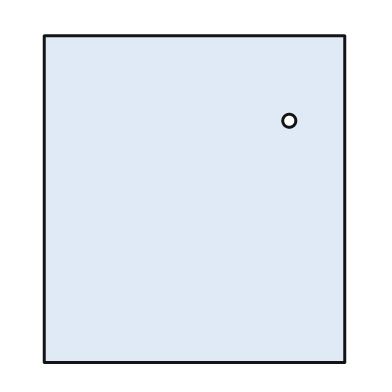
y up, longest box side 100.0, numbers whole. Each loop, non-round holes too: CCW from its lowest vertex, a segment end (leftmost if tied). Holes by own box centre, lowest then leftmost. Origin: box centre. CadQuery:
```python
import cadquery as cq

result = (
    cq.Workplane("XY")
    .moveTo(-46.0, -50.0)
    .lineTo(46.0, -50.0)
    .lineTo(46.0, 50.0)
    .lineTo(-46.0, 50.0)
    .close()
    .moveTo(29.0, 24.0)
    .circle(2.0)
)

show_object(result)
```